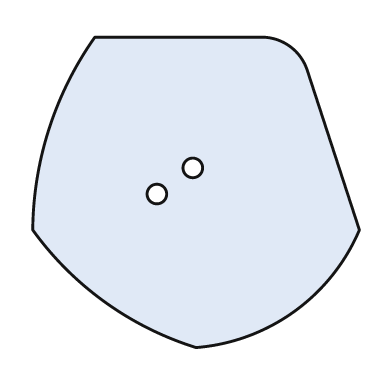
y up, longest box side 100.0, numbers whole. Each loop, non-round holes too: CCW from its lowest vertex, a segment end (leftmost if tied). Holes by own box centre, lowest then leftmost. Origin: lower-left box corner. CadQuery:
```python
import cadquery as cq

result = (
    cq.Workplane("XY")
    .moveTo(50.0, 0.0)
    .threePointArc((80.0, 11.0), (100.0, 36.0))
    .lineTo(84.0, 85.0)
    .threePointArc((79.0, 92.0), (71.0, 95.0))
    .lineTo(19.0, 95.0)
    .threePointArc((5.0, 67.0), (0.0, 36.0))
    .threePointArc((22.0, 14.0), (50.0, 0.0))
    .close()
    .moveTo(38.0, 47.0)
    .circle(3.0)
    .moveTo(49.0, 55.0)
    .circle(3.0)
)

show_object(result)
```